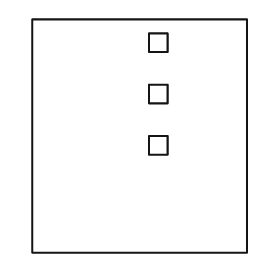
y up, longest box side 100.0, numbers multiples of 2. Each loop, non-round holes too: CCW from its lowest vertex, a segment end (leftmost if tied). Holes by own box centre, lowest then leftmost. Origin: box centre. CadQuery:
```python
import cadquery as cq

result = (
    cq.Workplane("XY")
    .moveTo(-46.0, -50.0)
    .lineTo(46.0, -50.0)
    .lineTo(46.0, 50.0)
    .lineTo(-46.0, 50.0)
    .close()
    .moveTo(4.0, -8.0)
    .lineTo(12.0, -8.0)
    .lineTo(12.0, 0.0)
    .lineTo(4.0, 0.0)
    .close()
    .moveTo(4.0, 14.0)
    .lineTo(12.0, 14.0)
    .lineTo(12.0, 22.0)
    .lineTo(4.0, 22.0)
    .close()
    .moveTo(4.0, 36.0)
    .lineTo(12.0, 36.0)
    .lineTo(12.0, 44.0)
    .lineTo(4.0, 44.0)
    .close()
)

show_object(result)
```